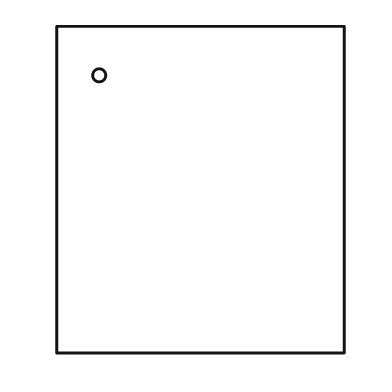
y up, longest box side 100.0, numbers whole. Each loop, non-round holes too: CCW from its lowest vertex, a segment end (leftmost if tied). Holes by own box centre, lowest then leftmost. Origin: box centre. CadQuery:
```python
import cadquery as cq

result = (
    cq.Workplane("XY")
    .moveTo(-44.0, -50.0)
    .lineTo(44.0, -50.0)
    .lineTo(44.0, 50.0)
    .lineTo(-44.0, 50.0)
    .close()
    .moveTo(-31.0, 35.0)
    .circle(2.0)
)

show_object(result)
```